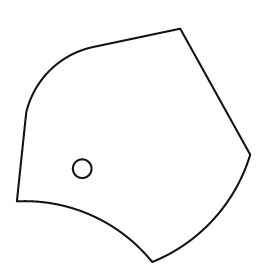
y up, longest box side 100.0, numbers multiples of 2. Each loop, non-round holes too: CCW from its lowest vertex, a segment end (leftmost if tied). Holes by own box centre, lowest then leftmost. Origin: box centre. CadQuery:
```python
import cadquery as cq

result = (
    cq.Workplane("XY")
    .moveTo(8.0, -50.0)
    .threePointArc((34.0, -32.0), (50.0, -4.0))
    .lineTo(20.0, 50.0)
    .lineTo(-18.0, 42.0)
    .threePointArc((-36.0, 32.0), (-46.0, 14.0))
    .lineTo(-50.0, -24.0)
    .threePointArc((-18.0, -30.0), (8.0, -50.0))
    .close()
    .moveTo(-22.0, -10.0)
    .circle(4.0)
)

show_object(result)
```